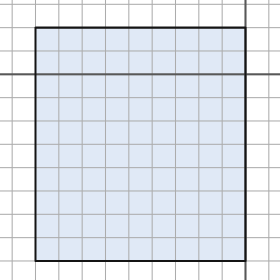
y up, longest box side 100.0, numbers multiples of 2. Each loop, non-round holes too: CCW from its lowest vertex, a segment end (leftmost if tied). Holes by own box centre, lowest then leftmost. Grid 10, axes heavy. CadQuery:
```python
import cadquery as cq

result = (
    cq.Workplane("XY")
    .moveTo(-90.0, -80.0)
    .lineTo(0.0, -80.0)
    .lineTo(0.0, 20.0)
    .lineTo(-90.0, 20.0)
    .close()
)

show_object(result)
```